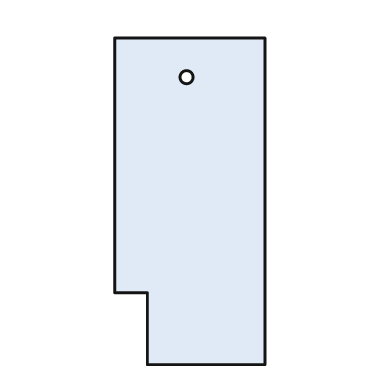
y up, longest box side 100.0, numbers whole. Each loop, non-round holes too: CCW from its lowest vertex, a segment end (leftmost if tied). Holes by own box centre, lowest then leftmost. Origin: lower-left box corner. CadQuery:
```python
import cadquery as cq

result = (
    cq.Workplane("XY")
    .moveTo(10.0, 0.0)
    .lineTo(46.0, 0.0)
    .lineTo(46.0, 100.0)
    .lineTo(0.0, 100.0)
    .lineTo(0.0, 22.0)
    .lineTo(10.0, 22.0)
    .close()
    .moveTo(22.0, 88.0)
    .circle(2.0)
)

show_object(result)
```